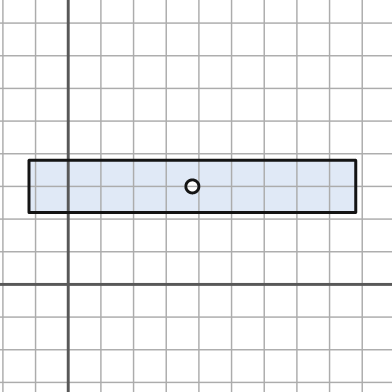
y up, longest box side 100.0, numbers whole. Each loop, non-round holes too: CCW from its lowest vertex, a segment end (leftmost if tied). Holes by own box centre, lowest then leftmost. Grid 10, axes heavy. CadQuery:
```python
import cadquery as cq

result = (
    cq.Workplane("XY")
    .moveTo(-12.0, 22.0)
    .lineTo(88.0, 22.0)
    .lineTo(88.0, 38.0)
    .lineTo(-12.0, 38.0)
    .close()
    .moveTo(38.0, 30.0)
    .circle(2.0)
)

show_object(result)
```